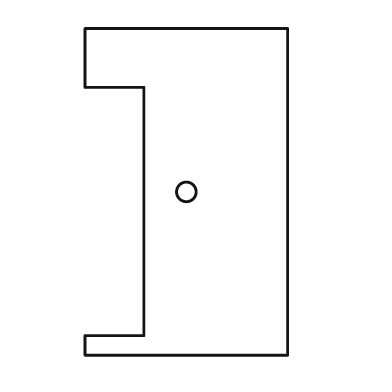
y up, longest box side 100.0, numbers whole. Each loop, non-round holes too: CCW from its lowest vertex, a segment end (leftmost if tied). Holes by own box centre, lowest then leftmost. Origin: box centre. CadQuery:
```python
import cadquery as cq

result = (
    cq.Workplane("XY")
    .moveTo(-31.0, -50.0)
    .lineTo(31.0, -50.0)
    .lineTo(31.0, 50.0)
    .lineTo(-31.0, 50.0)
    .lineTo(-31.0, 32.0)
    .lineTo(-13.0, 32.0)
    .lineTo(-13.0, -44.0)
    .lineTo(-31.0, -44.0)
    .close()
    .moveTo(0.0, 0.0)
    .circle(3.0)
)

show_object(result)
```